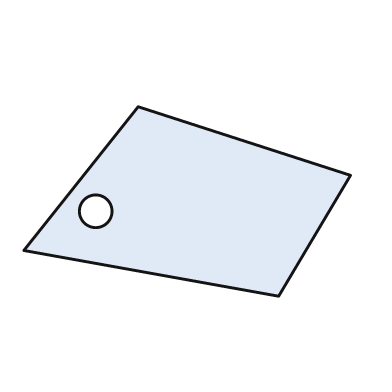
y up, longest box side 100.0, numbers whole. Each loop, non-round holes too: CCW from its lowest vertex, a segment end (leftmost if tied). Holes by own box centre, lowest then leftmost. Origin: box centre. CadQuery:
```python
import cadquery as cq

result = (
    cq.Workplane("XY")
    .moveTo(28.0, -29.0)
    .lineTo(50.0, 8.0)
    .lineTo(-15.0, 29.0)
    .lineTo(-50.0, -15.0)
    .close()
    .moveTo(-28.0, -3.0)
    .circle(5.0)
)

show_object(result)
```